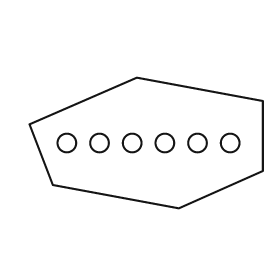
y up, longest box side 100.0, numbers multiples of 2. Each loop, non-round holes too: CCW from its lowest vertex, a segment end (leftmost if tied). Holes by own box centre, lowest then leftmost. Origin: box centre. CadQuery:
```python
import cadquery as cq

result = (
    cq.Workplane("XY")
    .moveTo(14.0, -28.0)
    .lineTo(50.0, -12.0)
    .lineTo(50.0, 18.0)
    .lineTo(-4.0, 28.0)
    .lineTo(-50.0, 8.0)
    .lineTo(-40.0, -18.0)
    .close()
    .moveTo(-34.0, 0.0)
    .circle(4.0)
    .moveTo(-20.0, 0.0)
    .circle(4.0)
    .moveTo(-6.0, 0.0)
    .circle(4.0)
    .moveTo(8.0, 0.0)
    .circle(4.0)
    .moveTo(22.0, 0.0)
    .circle(4.0)
    .moveTo(36.0, 0.0)
    .circle(4.0)
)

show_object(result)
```